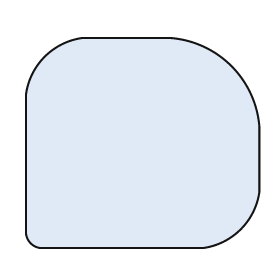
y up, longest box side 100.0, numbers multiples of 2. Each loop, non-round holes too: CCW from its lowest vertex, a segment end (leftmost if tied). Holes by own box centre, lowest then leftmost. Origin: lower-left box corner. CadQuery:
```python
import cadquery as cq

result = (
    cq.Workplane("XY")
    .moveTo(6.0, 0.0)
    .lineTo(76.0, 0.0)
    .threePointArc((92.0, 8.0), (100.0, 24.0))
    .lineTo(100.0, 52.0)
    .threePointArc((88.0, 78.0), (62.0, 90.0))
    .lineTo(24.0, 90.0)
    .threePointArc((8.0, 82.0), (0.0, 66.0))
    .lineTo(0.0, 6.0)
    .threePointArc((2.0, 2.0), (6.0, 0.0))
    .close()
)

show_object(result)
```